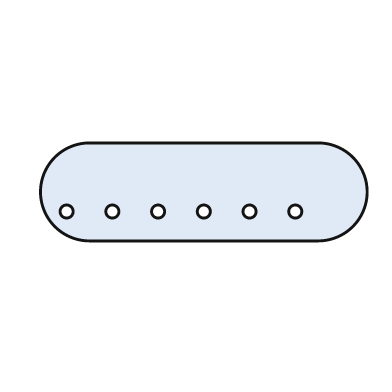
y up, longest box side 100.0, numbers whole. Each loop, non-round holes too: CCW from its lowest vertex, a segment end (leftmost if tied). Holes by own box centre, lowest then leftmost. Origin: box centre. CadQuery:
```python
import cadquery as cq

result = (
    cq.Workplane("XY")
    .moveTo(-35.0, -15.0)
    .lineTo(35.0, -15.0)
    .threePointArc((50.0, 0.0), (35.0, 15.0))
    .lineTo(-35.0, 15.0)
    .threePointArc((-50.0, 0.0), (-35.0, -15.0))
    .close()
    .moveTo(-42.0, -6.0)
    .circle(2.0)
    .moveTo(-28.0, -6.0)
    .circle(2.0)
    .moveTo(-14.0, -6.0)
    .circle(2.0)
    .moveTo(0.0, -6.0)
    .circle(2.0)
    .moveTo(14.0, -6.0)
    .circle(2.0)
    .moveTo(28.0, -6.0)
    .circle(2.0)
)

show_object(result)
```